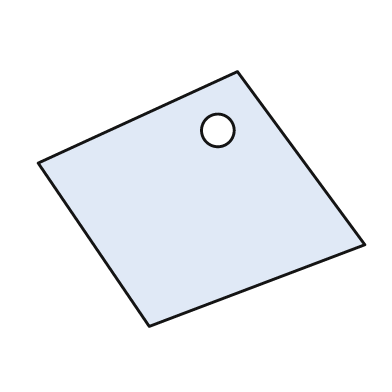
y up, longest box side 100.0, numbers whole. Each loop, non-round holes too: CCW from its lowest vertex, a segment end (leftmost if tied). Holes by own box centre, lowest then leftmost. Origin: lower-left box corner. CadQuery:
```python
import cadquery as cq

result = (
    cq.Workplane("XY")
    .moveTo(34.0, 0.0)
    .lineTo(100.0, 25.0)
    .lineTo(61.0, 78.0)
    .lineTo(0.0, 50.0)
    .close()
    .moveTo(55.0, 60.0)
    .circle(5.0)
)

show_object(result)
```